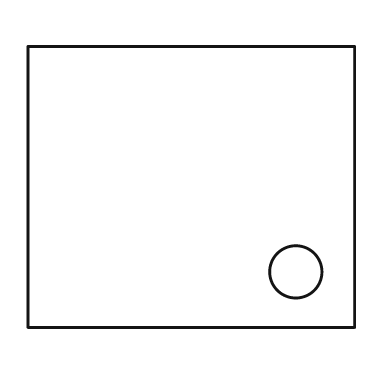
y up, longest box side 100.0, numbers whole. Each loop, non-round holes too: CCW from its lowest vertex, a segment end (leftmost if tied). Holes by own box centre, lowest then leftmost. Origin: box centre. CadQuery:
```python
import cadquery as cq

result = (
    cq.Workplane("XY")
    .moveTo(-50.0, -43.0)
    .lineTo(50.0, -43.0)
    .lineTo(50.0, 43.0)
    .lineTo(-50.0, 43.0)
    .close()
    .moveTo(32.0, -26.0)
    .circle(8.0)
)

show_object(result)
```